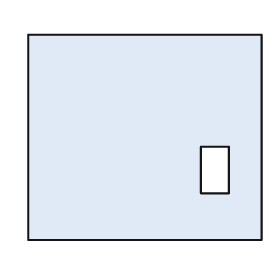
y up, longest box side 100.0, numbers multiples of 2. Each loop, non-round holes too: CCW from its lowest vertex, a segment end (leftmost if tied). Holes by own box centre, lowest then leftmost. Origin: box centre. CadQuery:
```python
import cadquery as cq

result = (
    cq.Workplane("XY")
    .moveTo(-50.0, -44.0)
    .lineTo(50.0, -44.0)
    .lineTo(50.0, 44.0)
    .lineTo(-50.0, 44.0)
    .close()
    .moveTo(24.0, -24.0)
    .lineTo(36.0, -24.0)
    .lineTo(36.0, -4.0)
    .lineTo(24.0, -4.0)
    .close()
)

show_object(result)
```